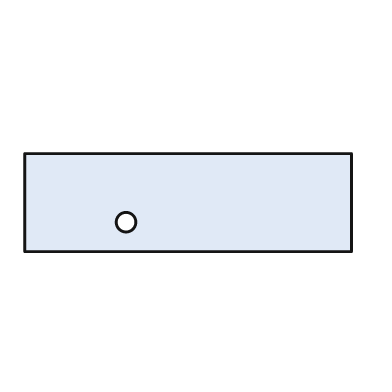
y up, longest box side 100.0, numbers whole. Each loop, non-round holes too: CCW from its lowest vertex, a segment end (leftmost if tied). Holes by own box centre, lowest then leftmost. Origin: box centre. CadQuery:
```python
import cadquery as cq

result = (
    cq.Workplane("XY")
    .moveTo(-50.0, -15.0)
    .lineTo(50.0, -15.0)
    .lineTo(50.0, 15.0)
    .lineTo(-50.0, 15.0)
    .close()
    .moveTo(-19.0, -6.0)
    .circle(3.0)
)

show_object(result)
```